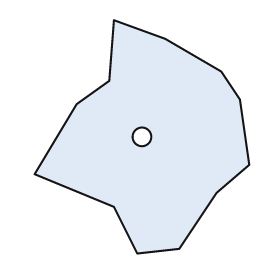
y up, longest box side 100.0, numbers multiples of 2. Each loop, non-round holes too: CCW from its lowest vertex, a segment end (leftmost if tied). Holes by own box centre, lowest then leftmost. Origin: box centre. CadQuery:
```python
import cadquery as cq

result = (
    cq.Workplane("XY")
    .moveTo(-2.0, -50.0)
    .lineTo(16.0, -48.0)
    .lineTo(32.0, -24.0)
    .lineTo(46.0, -12.0)
    .lineTo(42.0, 16.0)
    .lineTo(34.0, 28.0)
    .lineTo(10.0, 42.0)
    .lineTo(-12.0, 50.0)
    .lineTo(-14.0, 24.0)
    .lineTo(-28.0, 14.0)
    .lineTo(-46.0, -16.0)
    .lineTo(-12.0, -30.0)
    .close()
    .moveTo(0.0, 0.0)
    .circle(4.0)
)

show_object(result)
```